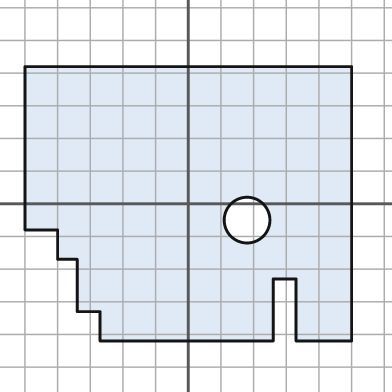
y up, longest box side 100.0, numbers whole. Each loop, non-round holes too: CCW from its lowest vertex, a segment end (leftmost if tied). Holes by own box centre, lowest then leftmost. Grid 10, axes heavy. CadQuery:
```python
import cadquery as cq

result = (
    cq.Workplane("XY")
    .moveTo(-27.0, -42.0)
    .lineTo(26.0, -42.0)
    .lineTo(26.0, -23.0)
    .lineTo(33.0, -23.0)
    .lineTo(33.0, -42.0)
    .lineTo(50.0, -42.0)
    .lineTo(50.0, 42.0)
    .lineTo(-50.0, 42.0)
    .lineTo(-50.0, -8.0)
    .lineTo(-40.0, -8.0)
    .lineTo(-40.0, -17.0)
    .lineTo(-34.0, -17.0)
    .lineTo(-34.0, -33.0)
    .lineTo(-27.0, -33.0)
    .close()
    .moveTo(18.0, -5.0)
    .circle(7.0)
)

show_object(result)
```